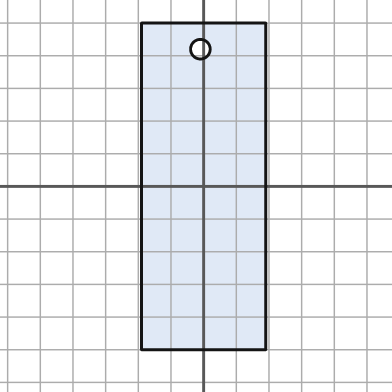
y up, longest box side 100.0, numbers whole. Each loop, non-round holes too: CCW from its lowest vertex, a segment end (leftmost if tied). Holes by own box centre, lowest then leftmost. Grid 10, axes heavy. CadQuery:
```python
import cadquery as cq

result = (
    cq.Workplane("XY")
    .moveTo(-19.0, -50.0)
    .lineTo(19.0, -50.0)
    .lineTo(19.0, 50.0)
    .lineTo(-19.0, 50.0)
    .close()
    .moveTo(-1.0, 42.0)
    .circle(3.0)
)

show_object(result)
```